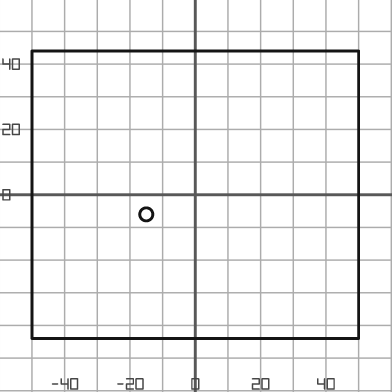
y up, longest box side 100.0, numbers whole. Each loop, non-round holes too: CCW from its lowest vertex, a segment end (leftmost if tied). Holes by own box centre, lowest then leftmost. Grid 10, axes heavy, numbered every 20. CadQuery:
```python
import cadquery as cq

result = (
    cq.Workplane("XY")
    .moveTo(-50.0, -44.0)
    .lineTo(50.0, -44.0)
    .lineTo(50.0, 44.0)
    .lineTo(-50.0, 44.0)
    .close()
    .moveTo(-15.0, -6.0)
    .circle(2.0)
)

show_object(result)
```